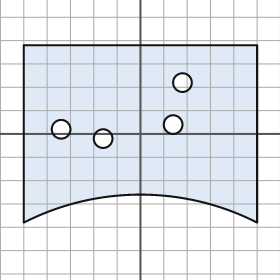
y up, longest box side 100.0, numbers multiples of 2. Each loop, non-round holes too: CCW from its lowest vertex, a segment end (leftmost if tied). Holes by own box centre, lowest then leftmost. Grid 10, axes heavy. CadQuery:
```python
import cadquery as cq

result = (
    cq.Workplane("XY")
    .moveTo(-50.0, -38.0)
    .threePointArc((0.0, -26.0), (50.0, -38.0))
    .lineTo(50.0, 38.0)
    .lineTo(-50.0, 38.0)
    .close()
    .moveTo(-16.0, -2.0)
    .circle(4.0)
    .moveTo(-34.0, 2.0)
    .circle(4.0)
    .moveTo(14.0, 4.0)
    .circle(4.0)
    .moveTo(18.0, 22.0)
    .circle(4.0)
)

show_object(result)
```